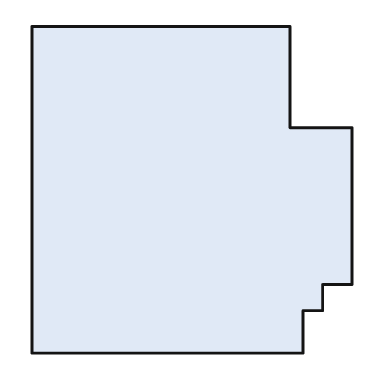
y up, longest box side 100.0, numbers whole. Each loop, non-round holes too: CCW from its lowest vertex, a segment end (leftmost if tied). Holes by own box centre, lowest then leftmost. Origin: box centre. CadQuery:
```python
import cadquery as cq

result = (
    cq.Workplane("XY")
    .moveTo(-49.0, -50.0)
    .lineTo(34.0, -50.0)
    .lineTo(34.0, -37.0)
    .lineTo(40.0, -37.0)
    .lineTo(40.0, -29.0)
    .lineTo(49.0, -29.0)
    .lineTo(49.0, 19.0)
    .lineTo(30.0, 19.0)
    .lineTo(30.0, 50.0)
    .lineTo(-49.0, 50.0)
    .close()
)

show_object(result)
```